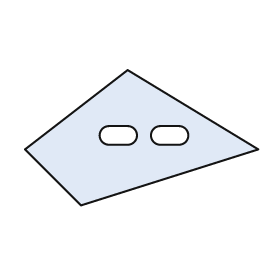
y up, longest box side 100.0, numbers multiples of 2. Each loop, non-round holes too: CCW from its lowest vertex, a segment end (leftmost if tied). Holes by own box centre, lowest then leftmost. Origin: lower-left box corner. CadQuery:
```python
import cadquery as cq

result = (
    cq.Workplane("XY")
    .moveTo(24.0, 0.0)
    .lineTo(100.0, 24.0)
    .lineTo(44.0, 58.0)
    .lineTo(0.0, 24.0)
    .close()
    .moveTo(36.0, 26.0)
    .lineTo(44.0, 26.0)
    .threePointArc((48.0, 30.0), (44.0, 34.0))
    .lineTo(36.0, 34.0)
    .threePointArc((32.0, 30.0), (36.0, 26.0))
    .close()
    .moveTo(58.0, 26.0)
    .lineTo(66.0, 26.0)
    .threePointArc((70.0, 30.0), (66.0, 34.0))
    .lineTo(58.0, 34.0)
    .threePointArc((54.0, 30.0), (58.0, 26.0))
    .close()
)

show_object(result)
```